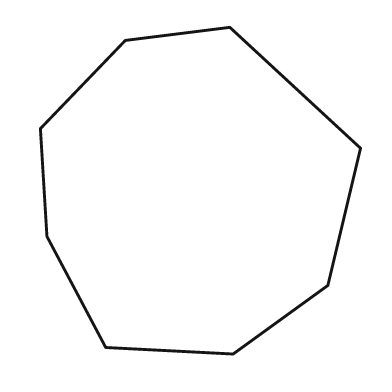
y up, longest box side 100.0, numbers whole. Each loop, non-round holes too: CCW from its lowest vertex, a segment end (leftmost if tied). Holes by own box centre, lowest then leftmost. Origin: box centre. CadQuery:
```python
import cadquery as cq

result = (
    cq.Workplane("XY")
    .moveTo(10.0, -50.0)
    .lineTo(39.0, -29.0)
    .lineTo(49.0, 13.0)
    .lineTo(9.0, 50.0)
    .lineTo(-23.0, 46.0)
    .lineTo(-49.0, 19.0)
    .lineTo(-47.0, -14.0)
    .lineTo(-29.0, -48.0)
    .close()
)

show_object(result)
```